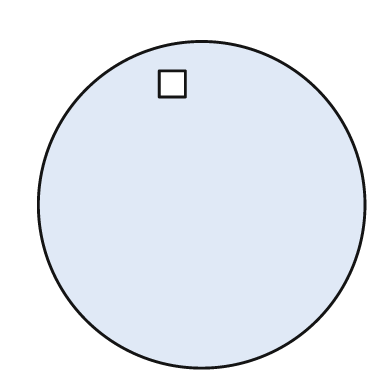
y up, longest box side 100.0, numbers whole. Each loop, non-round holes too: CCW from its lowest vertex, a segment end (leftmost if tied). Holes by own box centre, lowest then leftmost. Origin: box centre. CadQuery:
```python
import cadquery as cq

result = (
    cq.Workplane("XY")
    .moveTo(0.0, 0.0)
    .circle(50.0)
    .moveTo(-13.0, 33.0)
    .lineTo(-5.0, 33.0)
    .lineTo(-5.0, 41.0)
    .lineTo(-13.0, 41.0)
    .close()
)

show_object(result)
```